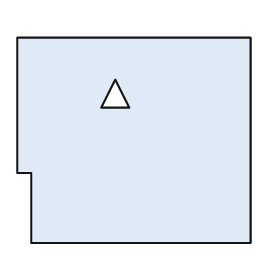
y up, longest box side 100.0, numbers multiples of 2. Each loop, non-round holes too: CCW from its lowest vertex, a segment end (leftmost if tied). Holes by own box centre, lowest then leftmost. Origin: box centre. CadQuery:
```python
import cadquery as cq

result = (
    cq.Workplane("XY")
    .moveTo(-44.0, -44.0)
    .lineTo(50.0, -44.0)
    .lineTo(50.0, 44.0)
    .lineTo(-50.0, 44.0)
    .lineTo(-50.0, -14.0)
    .lineTo(-44.0, -14.0)
    .close()
    .moveTo(-14.0, 14.0)
    .lineTo(-2.0, 14.0)
    .lineTo(-8.0, 26.0)
    .close()
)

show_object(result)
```